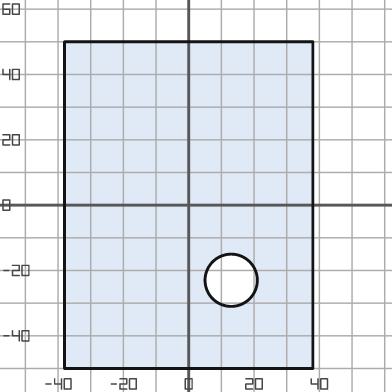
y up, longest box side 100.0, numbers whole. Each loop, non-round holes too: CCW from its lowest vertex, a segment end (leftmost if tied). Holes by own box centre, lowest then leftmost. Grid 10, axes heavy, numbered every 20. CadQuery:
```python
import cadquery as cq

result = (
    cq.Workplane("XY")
    .moveTo(-38.0, -50.0)
    .lineTo(38.0, -50.0)
    .lineTo(38.0, 50.0)
    .lineTo(-38.0, 50.0)
    .close()
    .moveTo(13.0, -23.0)
    .circle(8.0)
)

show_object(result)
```